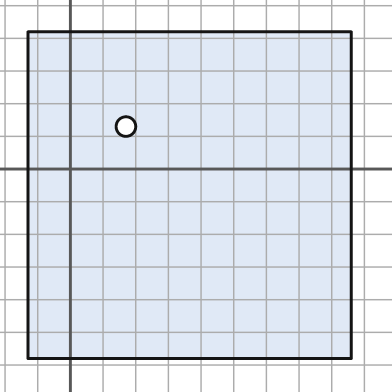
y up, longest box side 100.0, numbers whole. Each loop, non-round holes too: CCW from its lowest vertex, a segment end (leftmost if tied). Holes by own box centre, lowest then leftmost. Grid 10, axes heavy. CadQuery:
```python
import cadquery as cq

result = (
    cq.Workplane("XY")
    .moveTo(-13.0, -58.0)
    .lineTo(86.0, -58.0)
    .lineTo(86.0, 42.0)
    .lineTo(-13.0, 42.0)
    .close()
    .moveTo(17.0, 13.0)
    .circle(3.0)
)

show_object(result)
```